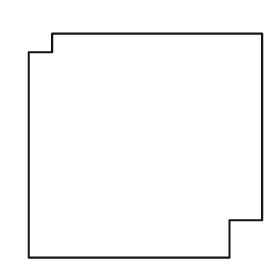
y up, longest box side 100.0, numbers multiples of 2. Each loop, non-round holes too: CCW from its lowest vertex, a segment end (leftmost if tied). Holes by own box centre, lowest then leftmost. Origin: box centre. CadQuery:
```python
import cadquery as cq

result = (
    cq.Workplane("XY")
    .moveTo(-50.0, -48.0)
    .lineTo(36.0, -48.0)
    .lineTo(36.0, -32.0)
    .lineTo(50.0, -32.0)
    .lineTo(50.0, 48.0)
    .lineTo(-40.0, 48.0)
    .lineTo(-40.0, 40.0)
    .lineTo(-50.0, 40.0)
    .close()
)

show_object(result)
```